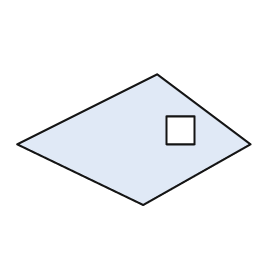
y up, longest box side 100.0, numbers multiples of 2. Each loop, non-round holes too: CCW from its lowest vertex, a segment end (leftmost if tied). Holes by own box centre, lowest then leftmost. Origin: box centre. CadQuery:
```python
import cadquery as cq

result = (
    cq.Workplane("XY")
    .moveTo(4.0, -28.0)
    .lineTo(50.0, -2.0)
    .lineTo(10.0, 28.0)
    .lineTo(-50.0, -2.0)
    .close()
    .moveTo(14.0, -2.0)
    .lineTo(26.0, -2.0)
    .lineTo(26.0, 10.0)
    .lineTo(14.0, 10.0)
    .close()
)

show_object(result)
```